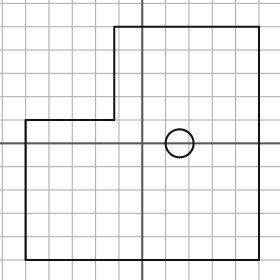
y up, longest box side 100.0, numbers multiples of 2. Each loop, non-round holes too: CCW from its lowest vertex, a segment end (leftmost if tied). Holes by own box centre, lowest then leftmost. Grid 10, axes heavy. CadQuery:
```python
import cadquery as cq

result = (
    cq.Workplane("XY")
    .moveTo(-50.0, -50.0)
    .lineTo(50.0, -50.0)
    .lineTo(50.0, 50.0)
    .lineTo(-12.0, 50.0)
    .lineTo(-12.0, 10.0)
    .lineTo(-50.0, 10.0)
    .close()
    .moveTo(16.0, 0.0)
    .circle(6.0)
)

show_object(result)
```